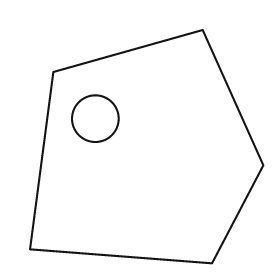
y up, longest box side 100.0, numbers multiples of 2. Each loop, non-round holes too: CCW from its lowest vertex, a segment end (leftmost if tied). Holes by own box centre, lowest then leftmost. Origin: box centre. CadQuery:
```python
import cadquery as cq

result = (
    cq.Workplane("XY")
    .moveTo(28.0, -50.0)
    .lineTo(50.0, -8.0)
    .lineTo(24.0, 50.0)
    .lineTo(-40.0, 32.0)
    .lineTo(-50.0, -44.0)
    .close()
    .moveTo(-22.0, 12.0)
    .circle(10.0)
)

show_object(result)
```